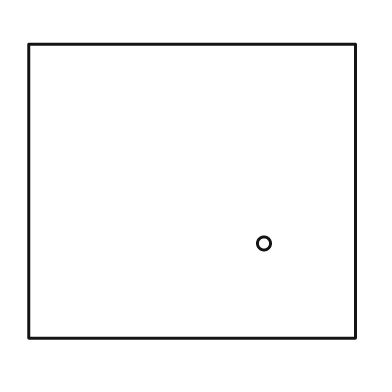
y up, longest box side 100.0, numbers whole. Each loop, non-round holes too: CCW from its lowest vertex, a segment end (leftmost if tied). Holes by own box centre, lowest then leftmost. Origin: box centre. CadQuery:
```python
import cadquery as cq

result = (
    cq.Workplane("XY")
    .moveTo(-50.0, -45.0)
    .lineTo(50.0, -45.0)
    .lineTo(50.0, 45.0)
    .lineTo(-50.0, 45.0)
    .close()
    .moveTo(22.0, -16.0)
    .circle(2.0)
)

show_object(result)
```